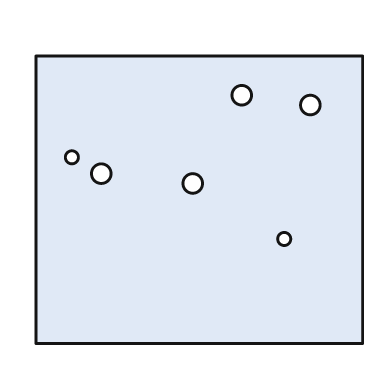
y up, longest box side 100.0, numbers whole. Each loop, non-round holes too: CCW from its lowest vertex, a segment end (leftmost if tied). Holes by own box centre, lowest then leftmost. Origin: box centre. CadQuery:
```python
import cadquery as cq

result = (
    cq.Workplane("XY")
    .moveTo(-50.0, -44.0)
    .lineTo(50.0, -44.0)
    .lineTo(50.0, 44.0)
    .lineTo(-50.0, 44.0)
    .close()
    .moveTo(26.0, -12.0)
    .circle(2.0)
    .moveTo(-2.0, 5.0)
    .circle(3.0)
    .moveTo(-30.0, 8.0)
    .circle(3.0)
    .moveTo(-39.0, 13.0)
    .circle(2.0)
    .moveTo(34.0, 29.0)
    .circle(3.0)
    .moveTo(13.0, 32.0)
    .circle(3.0)
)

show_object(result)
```